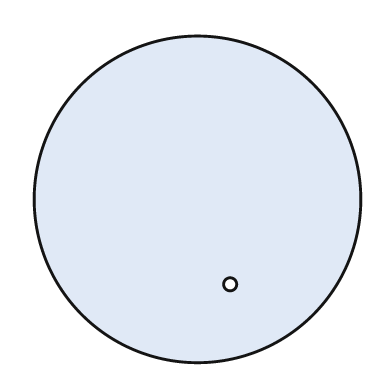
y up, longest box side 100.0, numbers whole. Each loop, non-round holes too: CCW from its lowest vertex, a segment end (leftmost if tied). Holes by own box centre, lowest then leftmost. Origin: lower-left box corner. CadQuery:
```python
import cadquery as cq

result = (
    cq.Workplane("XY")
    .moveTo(50.0, 50.0)
    .circle(50.0)
    .moveTo(60.0, 24.0)
    .circle(2.0)
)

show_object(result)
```